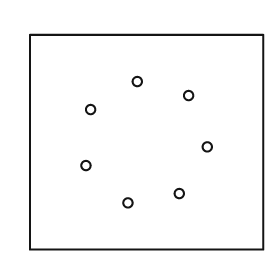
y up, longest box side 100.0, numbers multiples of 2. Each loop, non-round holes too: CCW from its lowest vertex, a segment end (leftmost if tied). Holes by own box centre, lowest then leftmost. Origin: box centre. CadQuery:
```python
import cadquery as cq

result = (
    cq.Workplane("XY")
    .moveTo(-50.0, -46.0)
    .lineTo(50.0, -46.0)
    .lineTo(50.0, 46.0)
    .lineTo(-50.0, 46.0)
    .close()
    .moveTo(-8.0, -26.0)
    .circle(2.0)
    .moveTo(14.0, -22.0)
    .circle(2.0)
    .moveTo(-26.0, -10.0)
    .circle(2.0)
    .moveTo(26.0, -2.0)
    .circle(2.0)
    .moveTo(-24.0, 14.0)
    .circle(2.0)
    .moveTo(18.0, 20.0)
    .circle(2.0)
    .moveTo(-4.0, 26.0)
    .circle(2.0)
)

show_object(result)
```